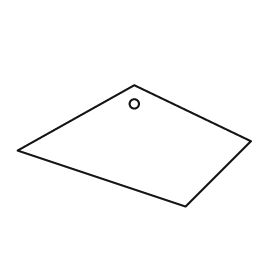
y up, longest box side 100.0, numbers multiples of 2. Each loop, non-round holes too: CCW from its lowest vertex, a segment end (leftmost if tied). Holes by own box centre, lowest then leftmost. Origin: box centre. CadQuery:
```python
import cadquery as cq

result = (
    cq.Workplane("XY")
    .moveTo(22.0, -26.0)
    .lineTo(50.0, 2.0)
    .lineTo(0.0, 26.0)
    .lineTo(-50.0, -2.0)
    .close()
    .moveTo(0.0, 18.0)
    .circle(2.0)
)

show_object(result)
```